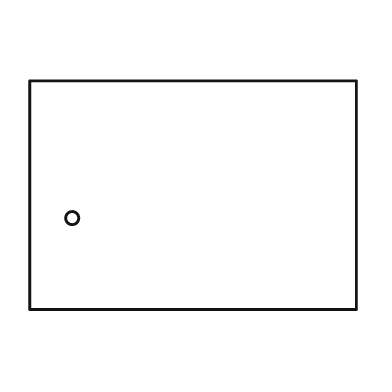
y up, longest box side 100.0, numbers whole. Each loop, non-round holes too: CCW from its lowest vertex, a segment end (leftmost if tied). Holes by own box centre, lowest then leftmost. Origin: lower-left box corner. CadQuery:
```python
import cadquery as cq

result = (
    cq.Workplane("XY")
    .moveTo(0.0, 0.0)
    .lineTo(100.0, 0.0)
    .lineTo(100.0, 70.0)
    .lineTo(0.0, 70.0)
    .close()
    .moveTo(13.0, 28.0)
    .circle(2.0)
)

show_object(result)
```